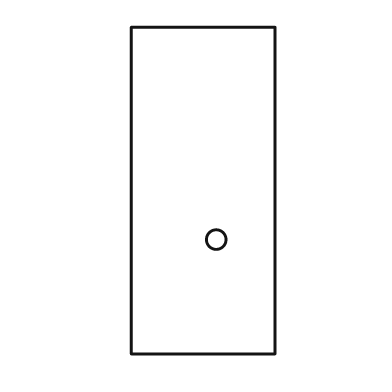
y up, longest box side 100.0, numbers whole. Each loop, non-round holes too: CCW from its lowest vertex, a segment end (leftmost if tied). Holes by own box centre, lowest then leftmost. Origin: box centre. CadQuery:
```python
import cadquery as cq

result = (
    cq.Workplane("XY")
    .moveTo(-22.0, -50.0)
    .lineTo(22.0, -50.0)
    .lineTo(22.0, 50.0)
    .lineTo(-22.0, 50.0)
    .close()
    .moveTo(4.0, -15.0)
    .circle(3.0)
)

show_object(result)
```